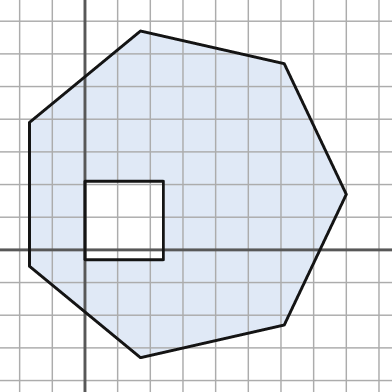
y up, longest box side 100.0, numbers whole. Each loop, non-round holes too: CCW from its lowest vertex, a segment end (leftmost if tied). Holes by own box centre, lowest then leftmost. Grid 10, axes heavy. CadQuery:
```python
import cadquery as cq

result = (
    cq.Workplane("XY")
    .moveTo(17.0, -33.0)
    .lineTo(61.0, -23.0)
    .lineTo(80.0, 17.0)
    .lineTo(61.0, 57.0)
    .lineTo(17.0, 67.0)
    .lineTo(-17.0, 39.0)
    .lineTo(-17.0, -5.0)
    .close()
    .moveTo(0.0, -3.0)
    .lineTo(24.0, -3.0)
    .lineTo(24.0, 21.0)
    .lineTo(0.0, 21.0)
    .close()
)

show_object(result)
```